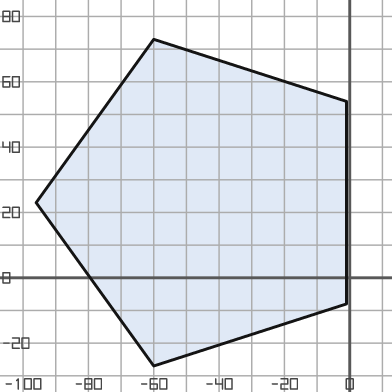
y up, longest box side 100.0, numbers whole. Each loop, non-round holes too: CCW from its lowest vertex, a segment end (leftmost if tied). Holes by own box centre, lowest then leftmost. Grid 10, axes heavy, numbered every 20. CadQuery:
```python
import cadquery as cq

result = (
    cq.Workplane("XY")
    .moveTo(-60.0, -27.0)
    .lineTo(-1.0, -8.0)
    .lineTo(-1.0, 54.0)
    .lineTo(-60.0, 73.0)
    .lineTo(-96.0, 23.0)
    .close()
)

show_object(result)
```